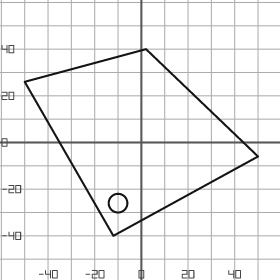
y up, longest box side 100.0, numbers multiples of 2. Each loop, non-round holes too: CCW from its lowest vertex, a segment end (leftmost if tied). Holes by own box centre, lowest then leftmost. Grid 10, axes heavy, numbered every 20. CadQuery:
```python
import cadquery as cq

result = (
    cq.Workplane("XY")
    .moveTo(-12.0, -40.0)
    .lineTo(50.0, -6.0)
    .lineTo(2.0, 40.0)
    .lineTo(-50.0, 26.0)
    .close()
    .moveTo(-10.0, -26.0)
    .circle(4.0)
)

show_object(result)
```